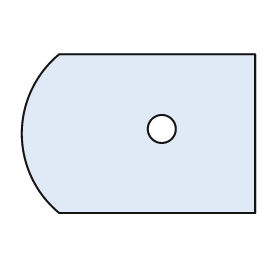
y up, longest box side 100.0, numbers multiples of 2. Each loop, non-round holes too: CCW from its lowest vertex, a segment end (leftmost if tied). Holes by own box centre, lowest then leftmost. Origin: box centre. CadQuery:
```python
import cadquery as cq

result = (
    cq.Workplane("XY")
    .moveTo(-34.0, -34.0)
    .lineTo(50.0, -34.0)
    .lineTo(50.0, 34.0)
    .lineTo(-34.0, 34.0)
    .threePointArc((-50.0, 0.0), (-34.0, -34.0))
    .close()
    .moveTo(10.0, 2.0)
    .circle(6.0)
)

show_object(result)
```